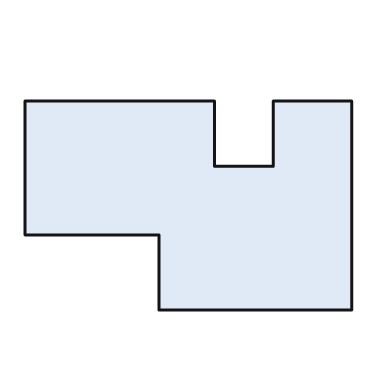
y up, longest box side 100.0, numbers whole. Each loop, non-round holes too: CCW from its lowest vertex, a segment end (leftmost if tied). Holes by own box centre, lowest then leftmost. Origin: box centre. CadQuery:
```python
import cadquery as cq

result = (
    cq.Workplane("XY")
    .moveTo(-9.0, -32.0)
    .lineTo(50.0, -32.0)
    .lineTo(50.0, 32.0)
    .lineTo(26.0, 32.0)
    .lineTo(26.0, 12.0)
    .lineTo(8.0, 12.0)
    .lineTo(8.0, 32.0)
    .lineTo(-50.0, 32.0)
    .lineTo(-50.0, -9.0)
    .lineTo(-9.0, -9.0)
    .close()
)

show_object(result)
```